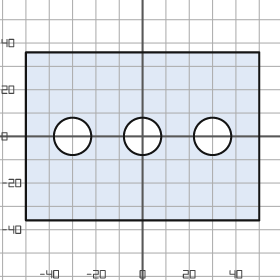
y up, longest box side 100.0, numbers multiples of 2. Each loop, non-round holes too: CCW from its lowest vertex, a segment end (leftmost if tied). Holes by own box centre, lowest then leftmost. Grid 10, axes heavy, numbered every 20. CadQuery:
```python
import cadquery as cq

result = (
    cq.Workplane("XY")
    .moveTo(-50.0, -36.0)
    .lineTo(50.0, -36.0)
    .lineTo(50.0, 36.0)
    .lineTo(-50.0, 36.0)
    .close()
    .moveTo(-30.0, 0.0)
    .circle(8.0)
    .moveTo(0.0, 0.0)
    .circle(8.0)
    .moveTo(30.0, 0.0)
    .circle(8.0)
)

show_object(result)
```